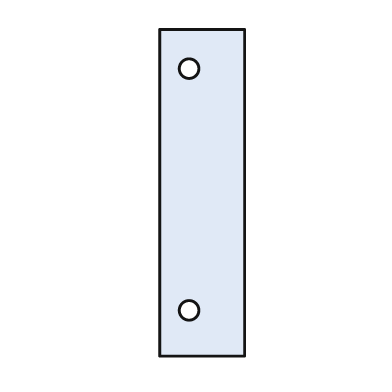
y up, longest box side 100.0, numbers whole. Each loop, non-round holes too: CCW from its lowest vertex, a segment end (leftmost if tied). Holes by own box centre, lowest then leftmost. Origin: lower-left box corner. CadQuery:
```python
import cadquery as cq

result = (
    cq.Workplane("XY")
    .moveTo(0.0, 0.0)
    .lineTo(26.0, 0.0)
    .lineTo(26.0, 100.0)
    .lineTo(0.0, 100.0)
    .close()
    .moveTo(9.0, 14.0)
    .circle(3.0)
    .moveTo(9.0, 88.0)
    .circle(3.0)
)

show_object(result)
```